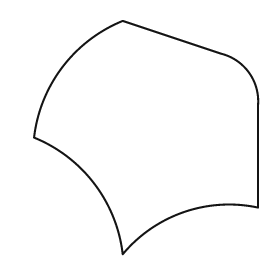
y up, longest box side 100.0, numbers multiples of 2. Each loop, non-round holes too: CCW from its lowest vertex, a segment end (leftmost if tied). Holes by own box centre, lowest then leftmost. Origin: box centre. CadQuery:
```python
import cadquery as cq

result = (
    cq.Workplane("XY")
    .moveTo(-10.0, -50.0)
    .threePointArc((16.0, -32.0), (48.0, -30.0))
    .lineTo(48.0, 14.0)
    .threePointArc((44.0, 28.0), (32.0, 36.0))
    .lineTo(-10.0, 50.0)
    .threePointArc((-36.0, 30.0), (-48.0, 0.0))
    .threePointArc((-22.0, -20.0), (-10.0, -50.0))
    .close()
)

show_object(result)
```